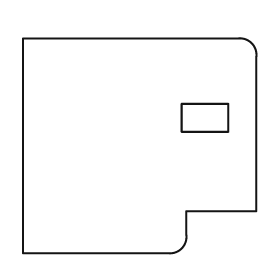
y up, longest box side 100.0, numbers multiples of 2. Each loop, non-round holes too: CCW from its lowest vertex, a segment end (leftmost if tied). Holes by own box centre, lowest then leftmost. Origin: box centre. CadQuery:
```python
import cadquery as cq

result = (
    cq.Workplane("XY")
    .moveTo(-50.0, -46.0)
    .lineTo(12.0, -46.0)
    .threePointArc((18.0, -44.0), (20.0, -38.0))
    .lineTo(20.0, -28.0)
    .lineTo(50.0, -28.0)
    .lineTo(50.0, 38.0)
    .threePointArc((48.0, 44.0), (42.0, 46.0))
    .lineTo(-50.0, 46.0)
    .close()
    .moveTo(18.0, 6.0)
    .lineTo(38.0, 6.0)
    .lineTo(38.0, 18.0)
    .lineTo(18.0, 18.0)
    .close()
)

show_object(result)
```